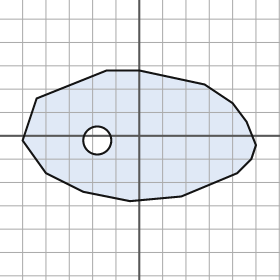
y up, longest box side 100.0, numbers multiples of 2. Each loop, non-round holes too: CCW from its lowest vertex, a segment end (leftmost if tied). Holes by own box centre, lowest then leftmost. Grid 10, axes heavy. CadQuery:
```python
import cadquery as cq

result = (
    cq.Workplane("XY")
    .moveTo(-4.0, -28.0)
    .lineTo(18.0, -26.0)
    .lineTo(42.0, -16.0)
    .lineTo(48.0, -10.0)
    .lineTo(50.0, -4.0)
    .lineTo(46.0, 6.0)
    .lineTo(40.0, 14.0)
    .lineTo(28.0, 22.0)
    .lineTo(0.0, 28.0)
    .lineTo(-14.0, 28.0)
    .lineTo(-44.0, 16.0)
    .lineTo(-50.0, -2.0)
    .lineTo(-40.0, -16.0)
    .lineTo(-24.0, -24.0)
    .close()
    .moveTo(-18.0, -2.0)
    .circle(6.0)
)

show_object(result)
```